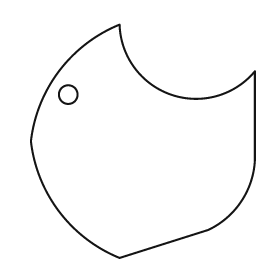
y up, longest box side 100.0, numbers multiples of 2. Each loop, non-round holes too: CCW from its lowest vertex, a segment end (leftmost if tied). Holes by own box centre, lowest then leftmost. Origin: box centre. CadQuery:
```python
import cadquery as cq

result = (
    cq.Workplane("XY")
    .moveTo(-10.0, -50.0)
    .lineTo(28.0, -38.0)
    .threePointArc((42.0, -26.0), (48.0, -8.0))
    .lineTo(48.0, 30.0)
    .threePointArc((12.0, 20.0), (-10.0, 50.0))
    .threePointArc((-36.0, 30.0), (-48.0, 0.0))
    .threePointArc((-36.0, -30.0), (-10.0, -50.0))
    .close()
    .moveTo(-32.0, 20.0)
    .circle(4.0)
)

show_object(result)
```